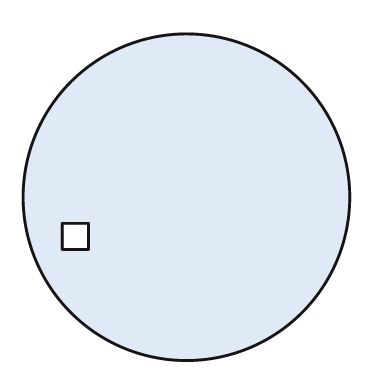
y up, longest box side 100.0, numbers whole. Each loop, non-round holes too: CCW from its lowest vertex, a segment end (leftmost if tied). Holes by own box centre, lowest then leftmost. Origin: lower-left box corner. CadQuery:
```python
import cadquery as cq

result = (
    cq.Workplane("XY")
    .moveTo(50.0, 50.0)
    .circle(50.0)
    .moveTo(12.0, 34.0)
    .lineTo(20.0, 34.0)
    .lineTo(20.0, 42.0)
    .lineTo(12.0, 42.0)
    .close()
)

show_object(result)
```